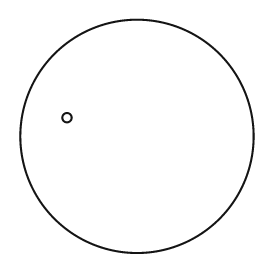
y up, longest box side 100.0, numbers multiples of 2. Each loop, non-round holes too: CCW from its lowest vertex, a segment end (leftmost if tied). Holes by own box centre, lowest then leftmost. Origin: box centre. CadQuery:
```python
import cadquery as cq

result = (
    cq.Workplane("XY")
    .moveTo(0.0, 0.0)
    .circle(50.0)
    .moveTo(-30.0, 8.0)
    .circle(2.0)
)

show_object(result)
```